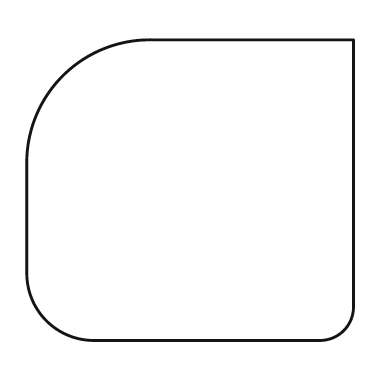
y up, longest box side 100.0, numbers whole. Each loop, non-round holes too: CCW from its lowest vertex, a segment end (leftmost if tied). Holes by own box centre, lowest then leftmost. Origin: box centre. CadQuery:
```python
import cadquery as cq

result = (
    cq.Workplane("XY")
    .moveTo(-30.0, -46.0)
    .lineTo(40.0, -46.0)
    .threePointArc((47.0, -43.0), (50.0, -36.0))
    .lineTo(50.0, 46.0)
    .lineTo(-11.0, 46.0)
    .threePointArc((-39.0, 35.0), (-50.0, 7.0))
    .lineTo(-50.0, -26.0)
    .threePointArc((-44.0, -40.0), (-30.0, -46.0))
    .close()
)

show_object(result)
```